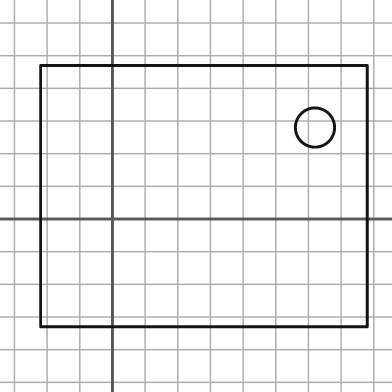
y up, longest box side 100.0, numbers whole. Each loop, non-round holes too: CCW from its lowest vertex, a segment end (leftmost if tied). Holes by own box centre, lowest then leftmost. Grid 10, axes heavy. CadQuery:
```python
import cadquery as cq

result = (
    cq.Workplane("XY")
    .moveTo(-22.0, -33.0)
    .lineTo(78.0, -33.0)
    .lineTo(78.0, 47.0)
    .lineTo(-22.0, 47.0)
    .close()
    .moveTo(62.0, 28.0)
    .circle(6.0)
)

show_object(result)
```